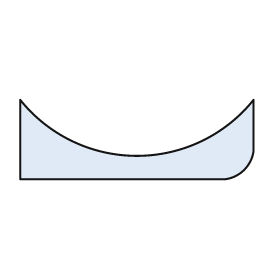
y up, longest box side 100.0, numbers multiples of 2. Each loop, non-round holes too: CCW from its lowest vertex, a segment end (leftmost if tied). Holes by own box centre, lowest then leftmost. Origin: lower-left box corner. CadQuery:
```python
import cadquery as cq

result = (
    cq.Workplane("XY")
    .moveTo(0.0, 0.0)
    .lineTo(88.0, 0.0)
    .threePointArc((96.0, 4.0), (100.0, 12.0))
    .lineTo(100.0, 34.0)
    .threePointArc((50.0, 10.0), (0.0, 34.0))
    .close()
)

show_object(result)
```